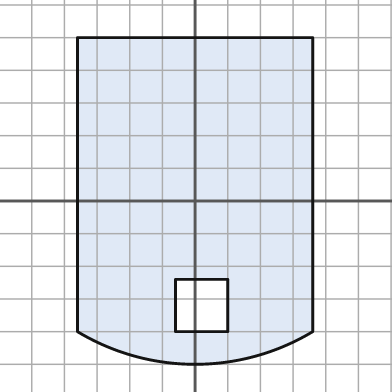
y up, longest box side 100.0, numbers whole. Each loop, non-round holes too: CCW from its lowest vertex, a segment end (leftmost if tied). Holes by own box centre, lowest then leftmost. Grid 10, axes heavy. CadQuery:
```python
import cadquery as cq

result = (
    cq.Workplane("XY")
    .moveTo(-36.0, -40.0)
    .threePointArc((0.0, -50.0), (36.0, -40.0))
    .lineTo(36.0, 50.0)
    .lineTo(-36.0, 50.0)
    .close()
    .moveTo(-6.0, -40.0)
    .lineTo(10.0, -40.0)
    .lineTo(10.0, -24.0)
    .lineTo(-6.0, -24.0)
    .close()
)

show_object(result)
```